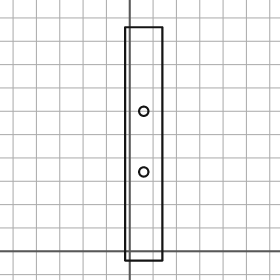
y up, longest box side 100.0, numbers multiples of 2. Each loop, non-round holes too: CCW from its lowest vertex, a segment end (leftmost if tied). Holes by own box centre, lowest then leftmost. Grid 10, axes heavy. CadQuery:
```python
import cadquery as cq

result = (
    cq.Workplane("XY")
    .moveTo(-2.0, -4.0)
    .lineTo(14.0, -4.0)
    .lineTo(14.0, 96.0)
    .lineTo(-2.0, 96.0)
    .close()
    .moveTo(6.0, 34.0)
    .circle(2.0)
    .moveTo(6.0, 60.0)
    .circle(2.0)
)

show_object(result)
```